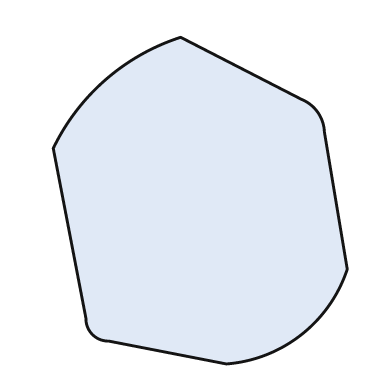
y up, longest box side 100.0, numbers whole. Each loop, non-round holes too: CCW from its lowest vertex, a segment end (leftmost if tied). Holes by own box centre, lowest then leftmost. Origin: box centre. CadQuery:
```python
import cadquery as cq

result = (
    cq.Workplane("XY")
    .moveTo(8.0, -50.0)
    .threePointArc((31.0, -41.0), (45.0, -21.0))
    .lineTo(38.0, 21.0)
    .threePointArc((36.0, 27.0), (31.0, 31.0))
    .lineTo(-6.0, 50.0)
    .threePointArc((-29.0, 37.0), (-45.0, 16.0))
    .lineTo(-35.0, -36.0)
    .threePointArc((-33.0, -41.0), (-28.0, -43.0))
    .close()
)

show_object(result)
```